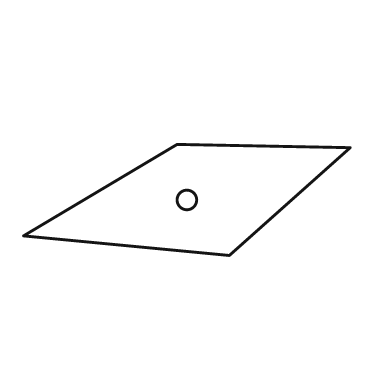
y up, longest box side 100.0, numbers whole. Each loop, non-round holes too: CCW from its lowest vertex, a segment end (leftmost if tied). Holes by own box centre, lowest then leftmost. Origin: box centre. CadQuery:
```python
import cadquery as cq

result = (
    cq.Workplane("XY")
    .moveTo(13.0, -17.0)
    .lineTo(50.0, 16.0)
    .lineTo(-3.0, 17.0)
    .lineTo(-50.0, -11.0)
    .close()
    .moveTo(0.0, 0.0)
    .circle(3.0)
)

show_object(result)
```